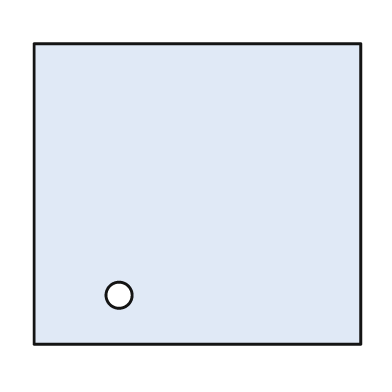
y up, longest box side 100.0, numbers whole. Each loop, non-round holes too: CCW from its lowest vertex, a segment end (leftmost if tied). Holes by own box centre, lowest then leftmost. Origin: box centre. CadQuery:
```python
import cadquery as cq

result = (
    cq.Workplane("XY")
    .moveTo(-50.0, -46.0)
    .lineTo(50.0, -46.0)
    .lineTo(50.0, 46.0)
    .lineTo(-50.0, 46.0)
    .close()
    .moveTo(-24.0, -31.0)
    .circle(4.0)
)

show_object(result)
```